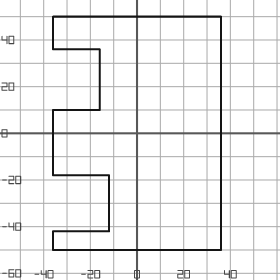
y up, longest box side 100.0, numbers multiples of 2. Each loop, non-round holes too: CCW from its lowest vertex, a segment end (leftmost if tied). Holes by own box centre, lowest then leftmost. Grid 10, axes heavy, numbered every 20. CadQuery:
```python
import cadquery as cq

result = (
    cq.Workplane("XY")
    .moveTo(-36.0, -50.0)
    .lineTo(36.0, -50.0)
    .lineTo(36.0, 50.0)
    .lineTo(-36.0, 50.0)
    .lineTo(-36.0, 36.0)
    .lineTo(-16.0, 36.0)
    .lineTo(-16.0, 10.0)
    .lineTo(-36.0, 10.0)
    .lineTo(-36.0, -18.0)
    .lineTo(-12.0, -18.0)
    .lineTo(-12.0, -42.0)
    .lineTo(-36.0, -42.0)
    .close()
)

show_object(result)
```